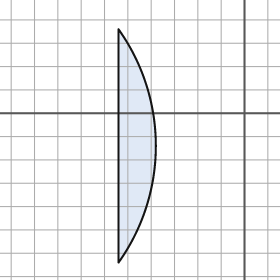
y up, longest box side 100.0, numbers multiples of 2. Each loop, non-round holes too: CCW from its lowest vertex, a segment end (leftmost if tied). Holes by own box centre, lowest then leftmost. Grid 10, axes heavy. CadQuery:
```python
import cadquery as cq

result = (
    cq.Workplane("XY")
    .moveTo(-54.0, -64.0)
    .threePointArc((-38.0, -14.0), (-54.0, 36.0))
    .close()
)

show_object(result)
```